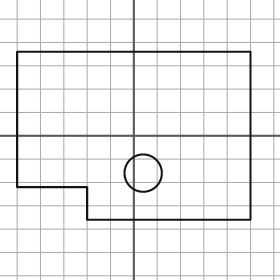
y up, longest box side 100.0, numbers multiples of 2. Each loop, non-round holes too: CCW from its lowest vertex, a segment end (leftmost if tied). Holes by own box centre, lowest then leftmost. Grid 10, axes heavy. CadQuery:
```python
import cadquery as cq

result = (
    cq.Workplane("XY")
    .moveTo(-20.0, -36.0)
    .lineTo(50.0, -36.0)
    .lineTo(50.0, 36.0)
    .lineTo(-50.0, 36.0)
    .lineTo(-50.0, -22.0)
    .lineTo(-20.0, -22.0)
    .close()
    .moveTo(4.0, -16.0)
    .circle(8.0)
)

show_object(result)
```